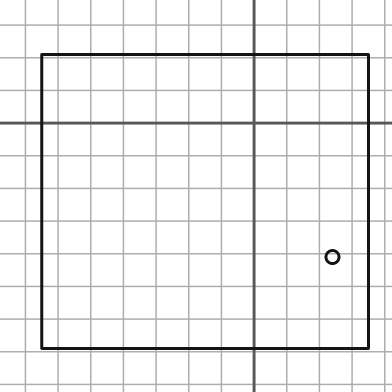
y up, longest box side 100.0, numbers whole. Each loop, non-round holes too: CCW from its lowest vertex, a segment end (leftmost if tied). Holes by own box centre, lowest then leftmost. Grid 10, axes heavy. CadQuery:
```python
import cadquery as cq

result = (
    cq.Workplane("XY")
    .moveTo(-65.0, -69.0)
    .lineTo(35.0, -69.0)
    .lineTo(35.0, 21.0)
    .lineTo(-65.0, 21.0)
    .close()
    .moveTo(24.0, -41.0)
    .circle(2.0)
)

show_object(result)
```